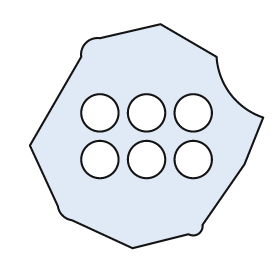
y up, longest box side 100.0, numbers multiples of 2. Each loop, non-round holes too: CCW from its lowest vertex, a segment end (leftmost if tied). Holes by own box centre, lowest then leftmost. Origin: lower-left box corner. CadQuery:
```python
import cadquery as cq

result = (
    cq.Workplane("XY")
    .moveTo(44.0, 0.0)
    .lineTo(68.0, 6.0)
    .threePointArc((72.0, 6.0), (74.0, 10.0))
    .lineTo(92.0, 36.0)
    .lineTo(100.0, 56.0)
    .threePointArc((86.0, 66.0), (80.0, 82.0))
    .lineTo(56.0, 96.0)
    .lineTo(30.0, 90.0)
    .threePointArc((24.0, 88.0), (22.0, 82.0))
    .lineTo(0.0, 44.0)
    .lineTo(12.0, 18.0)
    .threePointArc((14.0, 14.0), (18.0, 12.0))
    .close()
    .moveTo(30.0, 38.0)
    .circle(8.0)
    .moveTo(50.0, 38.0)
    .circle(8.0)
    .moveTo(70.0, 38.0)
    .circle(8.0)
    .moveTo(30.0, 58.0)
    .circle(8.0)
    .moveTo(50.0, 58.0)
    .circle(8.0)
    .moveTo(70.0, 58.0)
    .circle(8.0)
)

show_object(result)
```